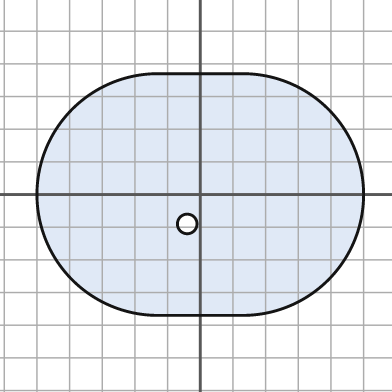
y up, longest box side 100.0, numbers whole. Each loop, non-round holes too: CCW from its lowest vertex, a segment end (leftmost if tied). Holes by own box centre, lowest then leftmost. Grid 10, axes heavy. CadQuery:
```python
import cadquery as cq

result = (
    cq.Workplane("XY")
    .moveTo(-13.0, -37.0)
    .lineTo(13.0, -37.0)
    .threePointArc((50.0, 0.0), (13.0, 37.0))
    .lineTo(-13.0, 37.0)
    .threePointArc((-50.0, 0.0), (-13.0, -37.0))
    .close()
    .moveTo(-4.0, -9.0)
    .circle(3.0)
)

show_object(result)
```